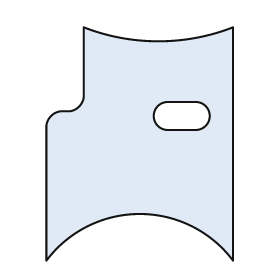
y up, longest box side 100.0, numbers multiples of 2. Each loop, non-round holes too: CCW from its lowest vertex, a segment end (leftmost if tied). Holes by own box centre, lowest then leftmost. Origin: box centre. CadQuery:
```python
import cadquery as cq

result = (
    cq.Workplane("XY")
    .moveTo(-40.0, -50.0)
    .threePointArc((0.0, -30.0), (40.0, -50.0))
    .lineTo(40.0, 50.0)
    .threePointArc((8.0, 44.0), (-24.0, 50.0))
    .lineTo(-24.0, 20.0)
    .threePointArc((-26.0, 16.0), (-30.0, 14.0))
    .lineTo(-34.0, 14.0)
    .threePointArc((-38.0, 12.0), (-40.0, 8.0))
    .close()
    .moveTo(12.0, 6.0)
    .lineTo(24.0, 6.0)
    .threePointArc((30.0, 12.0), (24.0, 18.0))
    .lineTo(12.0, 18.0)
    .threePointArc((6.0, 12.0), (12.0, 6.0))
    .close()
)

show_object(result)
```